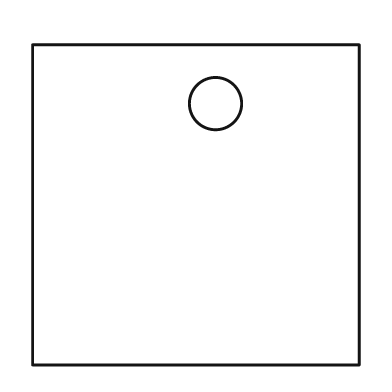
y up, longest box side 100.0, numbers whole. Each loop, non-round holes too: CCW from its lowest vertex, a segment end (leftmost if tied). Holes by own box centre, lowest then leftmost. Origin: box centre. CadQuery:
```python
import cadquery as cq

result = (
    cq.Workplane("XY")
    .moveTo(-50.0, -49.0)
    .lineTo(50.0, -49.0)
    .lineTo(50.0, 49.0)
    .lineTo(-50.0, 49.0)
    .close()
    .moveTo(6.0, 31.0)
    .circle(8.0)
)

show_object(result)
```